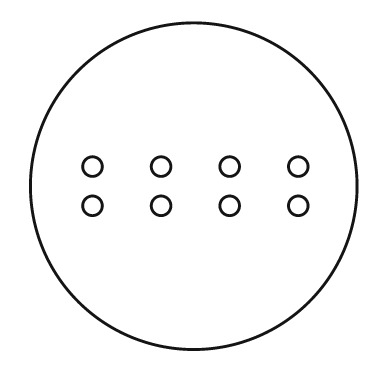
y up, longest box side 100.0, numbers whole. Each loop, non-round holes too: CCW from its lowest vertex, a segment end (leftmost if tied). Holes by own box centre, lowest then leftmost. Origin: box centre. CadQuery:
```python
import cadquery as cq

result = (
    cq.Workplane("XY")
    .moveTo(0.0, 0.0)
    .circle(50.0)
    .moveTo(-31.0, -6.0)
    .circle(3.0)
    .moveTo(-10.0, -6.0)
    .circle(3.0)
    .moveTo(11.0, -6.0)
    .circle(3.0)
    .moveTo(32.0, -6.0)
    .circle(3.0)
    .moveTo(-31.0, 6.0)
    .circle(3.0)
    .moveTo(-10.0, 6.0)
    .circle(3.0)
    .moveTo(11.0, 6.0)
    .circle(3.0)
    .moveTo(32.0, 6.0)
    .circle(3.0)
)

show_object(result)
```